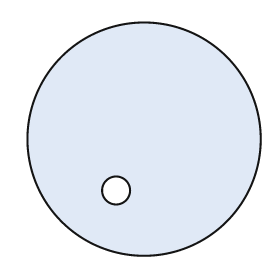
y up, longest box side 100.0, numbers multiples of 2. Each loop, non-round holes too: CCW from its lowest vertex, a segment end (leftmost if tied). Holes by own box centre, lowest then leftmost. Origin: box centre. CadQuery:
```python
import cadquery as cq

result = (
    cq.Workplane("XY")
    .moveTo(0.0, 0.0)
    .circle(50.0)
    .moveTo(-12.0, -22.0)
    .circle(6.0)
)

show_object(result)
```